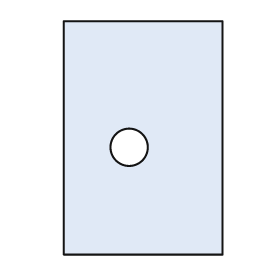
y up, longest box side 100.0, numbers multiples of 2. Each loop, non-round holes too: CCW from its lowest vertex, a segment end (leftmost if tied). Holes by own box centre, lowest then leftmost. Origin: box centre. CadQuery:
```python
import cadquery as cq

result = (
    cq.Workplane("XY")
    .moveTo(-34.0, -50.0)
    .lineTo(34.0, -50.0)
    .lineTo(34.0, 50.0)
    .lineTo(-34.0, 50.0)
    .close()
    .moveTo(-6.0, -4.0)
    .circle(8.0)
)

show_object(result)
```